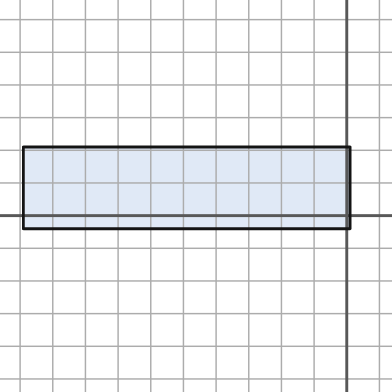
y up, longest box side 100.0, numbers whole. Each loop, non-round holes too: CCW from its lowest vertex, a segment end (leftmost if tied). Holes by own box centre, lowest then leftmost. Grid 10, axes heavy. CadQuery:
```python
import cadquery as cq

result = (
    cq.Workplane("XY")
    .moveTo(-99.0, -4.0)
    .lineTo(1.0, -4.0)
    .lineTo(1.0, 21.0)
    .lineTo(-99.0, 21.0)
    .close()
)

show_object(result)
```